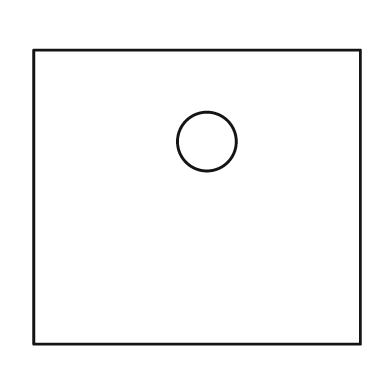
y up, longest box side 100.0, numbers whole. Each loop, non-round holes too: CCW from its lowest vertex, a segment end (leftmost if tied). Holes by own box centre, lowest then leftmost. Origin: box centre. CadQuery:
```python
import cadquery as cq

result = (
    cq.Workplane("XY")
    .moveTo(-50.0, -45.0)
    .lineTo(50.0, -45.0)
    .lineTo(50.0, 45.0)
    .lineTo(-50.0, 45.0)
    .close()
    .moveTo(3.0, 17.0)
    .circle(9.0)
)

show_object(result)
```